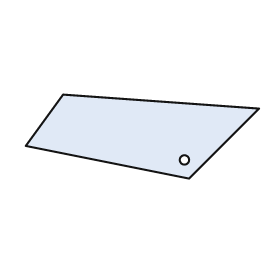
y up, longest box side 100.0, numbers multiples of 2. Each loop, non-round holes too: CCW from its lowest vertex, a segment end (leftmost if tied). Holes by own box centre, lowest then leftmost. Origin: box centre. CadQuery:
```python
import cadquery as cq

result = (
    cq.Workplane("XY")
    .moveTo(20.0, -18.0)
    .lineTo(50.0, 12.0)
    .lineTo(-34.0, 18.0)
    .lineTo(-50.0, -4.0)
    .close()
    .moveTo(18.0, -10.0)
    .circle(2.0)
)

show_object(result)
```